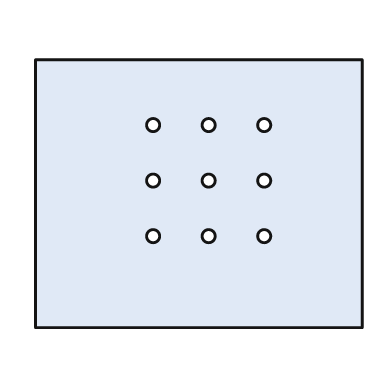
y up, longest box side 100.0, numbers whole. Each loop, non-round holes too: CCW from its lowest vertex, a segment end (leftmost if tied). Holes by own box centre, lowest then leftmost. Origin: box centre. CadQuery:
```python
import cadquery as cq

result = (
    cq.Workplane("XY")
    .moveTo(-50.0, -41.0)
    .lineTo(50.0, -41.0)
    .lineTo(50.0, 41.0)
    .lineTo(-50.0, 41.0)
    .close()
    .moveTo(-14.0, -13.0)
    .circle(2.0)
    .moveTo(3.0, -13.0)
    .circle(2.0)
    .moveTo(20.0, -13.0)
    .circle(2.0)
    .moveTo(-14.0, 4.0)
    .circle(2.0)
    .moveTo(3.0, 4.0)
    .circle(2.0)
    .moveTo(20.0, 4.0)
    .circle(2.0)
    .moveTo(-14.0, 21.0)
    .circle(2.0)
    .moveTo(3.0, 21.0)
    .circle(2.0)
    .moveTo(20.0, 21.0)
    .circle(2.0)
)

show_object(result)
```